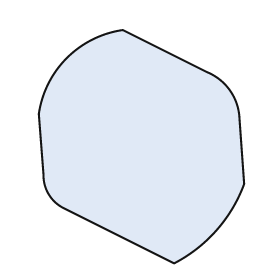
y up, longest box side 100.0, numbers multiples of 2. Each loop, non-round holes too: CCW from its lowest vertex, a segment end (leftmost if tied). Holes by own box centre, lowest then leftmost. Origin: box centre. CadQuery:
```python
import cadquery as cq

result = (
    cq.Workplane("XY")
    .moveTo(14.0, -50.0)
    .threePointArc((32.0, -36.0), (44.0, -16.0))
    .lineTo(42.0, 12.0)
    .threePointArc((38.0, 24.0), (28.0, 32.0))
    .lineTo(-8.0, 50.0)
    .threePointArc((-32.0, 38.0), (-44.0, 14.0))
    .lineTo(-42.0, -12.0)
    .threePointArc((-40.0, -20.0), (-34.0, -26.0))
    .close()
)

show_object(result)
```